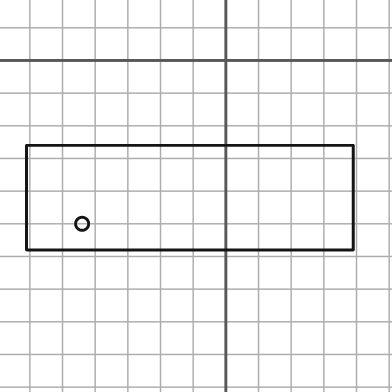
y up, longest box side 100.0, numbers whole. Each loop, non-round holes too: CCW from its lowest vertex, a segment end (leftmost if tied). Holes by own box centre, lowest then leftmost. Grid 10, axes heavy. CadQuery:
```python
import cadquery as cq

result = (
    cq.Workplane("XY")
    .moveTo(-61.0, -58.0)
    .lineTo(39.0, -58.0)
    .lineTo(39.0, -26.0)
    .lineTo(-61.0, -26.0)
    .close()
    .moveTo(-44.0, -50.0)
    .circle(2.0)
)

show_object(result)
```